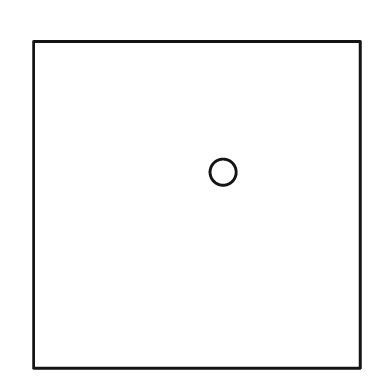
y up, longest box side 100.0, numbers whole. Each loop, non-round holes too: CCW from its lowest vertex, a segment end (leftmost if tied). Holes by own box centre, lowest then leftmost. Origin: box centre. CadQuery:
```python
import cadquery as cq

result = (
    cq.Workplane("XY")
    .moveTo(-50.0, -50.0)
    .lineTo(50.0, -50.0)
    .lineTo(50.0, 50.0)
    .lineTo(-50.0, 50.0)
    .close()
    .moveTo(8.0, 10.0)
    .circle(4.0)
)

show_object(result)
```